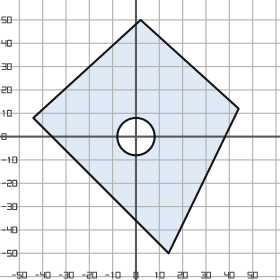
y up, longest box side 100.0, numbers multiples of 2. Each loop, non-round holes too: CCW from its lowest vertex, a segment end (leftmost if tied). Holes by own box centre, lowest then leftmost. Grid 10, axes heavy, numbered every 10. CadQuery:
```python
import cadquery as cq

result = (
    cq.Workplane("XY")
    .moveTo(14.0, -50.0)
    .lineTo(44.0, 12.0)
    .lineTo(2.0, 50.0)
    .lineTo(-44.0, 8.0)
    .close()
    .moveTo(0.0, 0.0)
    .circle(8.0)
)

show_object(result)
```